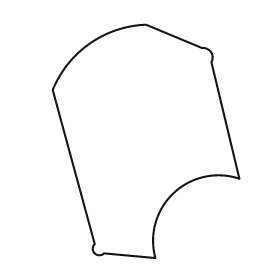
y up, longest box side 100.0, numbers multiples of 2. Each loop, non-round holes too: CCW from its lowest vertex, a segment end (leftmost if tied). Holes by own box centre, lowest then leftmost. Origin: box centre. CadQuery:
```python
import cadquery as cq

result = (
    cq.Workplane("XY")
    .moveTo(4.0, -50.0)
    .threePointArc((12.0, -22.0), (40.0, -16.0))
    .lineTo(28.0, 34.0)
    .threePointArc((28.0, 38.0), (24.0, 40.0))
    .lineTo(0.0, 50.0)
    .threePointArc((-24.0, 42.0), (-40.0, 22.0))
    .lineTo(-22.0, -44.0)
    .threePointArc((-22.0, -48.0), (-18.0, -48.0))
    .close()
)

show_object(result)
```